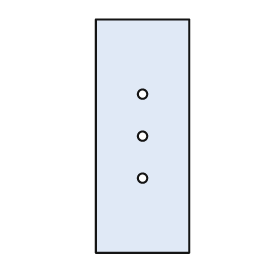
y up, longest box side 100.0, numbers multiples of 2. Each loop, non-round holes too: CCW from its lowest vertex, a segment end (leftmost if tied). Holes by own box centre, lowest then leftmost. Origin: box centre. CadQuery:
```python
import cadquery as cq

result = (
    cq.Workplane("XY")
    .moveTo(-20.0, -50.0)
    .lineTo(20.0, -50.0)
    .lineTo(20.0, 50.0)
    .lineTo(-20.0, 50.0)
    .close()
    .moveTo(0.0, -18.0)
    .circle(2.0)
    .moveTo(0.0, 0.0)
    .circle(2.0)
    .moveTo(0.0, 18.0)
    .circle(2.0)
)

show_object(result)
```